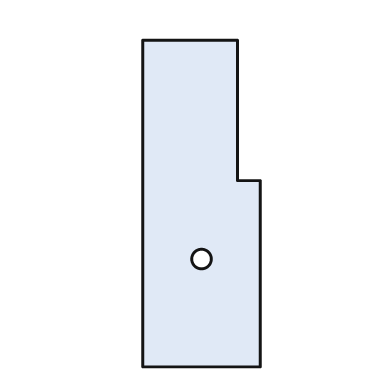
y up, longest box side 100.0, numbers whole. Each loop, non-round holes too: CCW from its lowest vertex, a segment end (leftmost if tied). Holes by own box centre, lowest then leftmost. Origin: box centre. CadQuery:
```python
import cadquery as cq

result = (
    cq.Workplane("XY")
    .moveTo(-18.0, -50.0)
    .lineTo(18.0, -50.0)
    .lineTo(18.0, 7.0)
    .lineTo(11.0, 7.0)
    .lineTo(11.0, 50.0)
    .lineTo(-18.0, 50.0)
    .close()
    .moveTo(0.0, -17.0)
    .circle(3.0)
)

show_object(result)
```